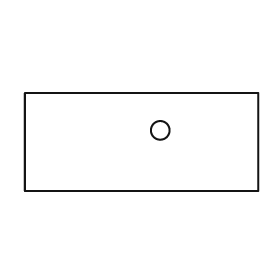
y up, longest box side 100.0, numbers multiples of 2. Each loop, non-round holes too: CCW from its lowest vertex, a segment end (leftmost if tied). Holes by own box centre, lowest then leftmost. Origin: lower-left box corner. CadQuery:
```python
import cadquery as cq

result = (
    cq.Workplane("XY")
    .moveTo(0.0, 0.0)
    .lineTo(100.0, 0.0)
    .lineTo(100.0, 42.0)
    .lineTo(0.0, 42.0)
    .close()
    .moveTo(58.0, 26.0)
    .circle(4.0)
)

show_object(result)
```